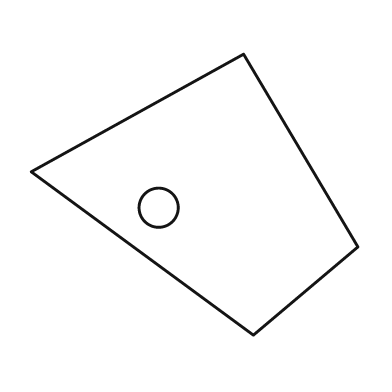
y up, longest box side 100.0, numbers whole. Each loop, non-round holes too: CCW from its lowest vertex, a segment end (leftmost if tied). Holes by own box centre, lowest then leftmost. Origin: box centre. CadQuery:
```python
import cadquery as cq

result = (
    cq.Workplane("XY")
    .moveTo(18.0, -43.0)
    .lineTo(50.0, -16.0)
    .lineTo(15.0, 43.0)
    .lineTo(-50.0, 7.0)
    .close()
    .moveTo(-11.0, -4.0)
    .circle(6.0)
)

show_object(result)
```